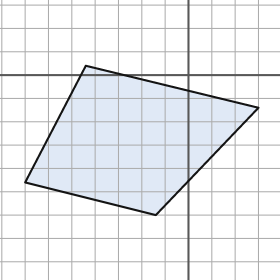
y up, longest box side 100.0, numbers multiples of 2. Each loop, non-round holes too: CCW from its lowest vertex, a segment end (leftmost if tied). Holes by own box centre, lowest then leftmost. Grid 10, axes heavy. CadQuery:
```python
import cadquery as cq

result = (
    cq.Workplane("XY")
    .moveTo(-14.0, -60.0)
    .lineTo(30.0, -14.0)
    .lineTo(-44.0, 4.0)
    .lineTo(-70.0, -46.0)
    .close()
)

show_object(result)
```